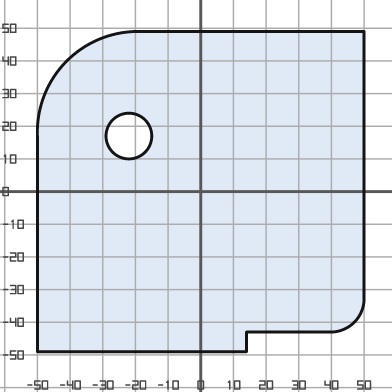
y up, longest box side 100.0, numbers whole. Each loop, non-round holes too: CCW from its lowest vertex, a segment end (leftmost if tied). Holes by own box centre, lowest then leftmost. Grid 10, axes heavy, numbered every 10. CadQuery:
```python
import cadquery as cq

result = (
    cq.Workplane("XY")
    .moveTo(-50.0, -49.0)
    .lineTo(14.0, -49.0)
    .lineTo(14.0, -43.0)
    .lineTo(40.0, -43.0)
    .threePointArc((47.0, -40.0), (50.0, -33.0))
    .lineTo(50.0, 49.0)
    .lineTo(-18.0, 49.0)
    .threePointArc((-41.0, 40.0), (-50.0, 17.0))
    .close()
    .moveTo(-22.0, 17.0)
    .circle(7.0)
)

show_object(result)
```